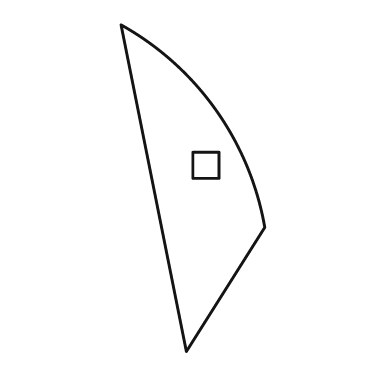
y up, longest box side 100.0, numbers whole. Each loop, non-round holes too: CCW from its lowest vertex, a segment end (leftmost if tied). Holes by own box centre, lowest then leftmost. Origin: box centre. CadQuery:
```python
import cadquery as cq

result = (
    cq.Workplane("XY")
    .moveTo(-2.0, -50.0)
    .lineTo(22.0, -12.0)
    .threePointArc((7.0, 24.0), (-22.0, 50.0))
    .close()
    .moveTo(0.0, 3.0)
    .lineTo(8.0, 3.0)
    .lineTo(8.0, 11.0)
    .lineTo(0.0, 11.0)
    .close()
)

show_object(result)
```